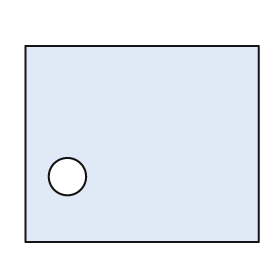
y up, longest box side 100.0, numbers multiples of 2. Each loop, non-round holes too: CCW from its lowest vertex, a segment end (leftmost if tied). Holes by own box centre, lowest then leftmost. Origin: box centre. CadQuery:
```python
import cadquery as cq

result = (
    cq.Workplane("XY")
    .moveTo(-50.0, -42.0)
    .lineTo(50.0, -42.0)
    .lineTo(50.0, 42.0)
    .lineTo(-50.0, 42.0)
    .close()
    .moveTo(-32.0, -14.0)
    .circle(8.0)
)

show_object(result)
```